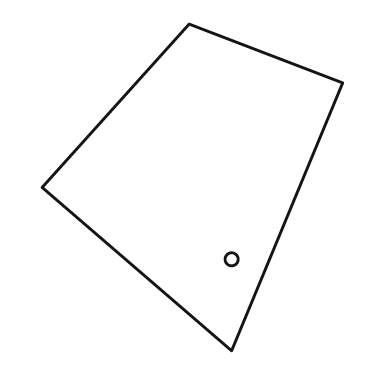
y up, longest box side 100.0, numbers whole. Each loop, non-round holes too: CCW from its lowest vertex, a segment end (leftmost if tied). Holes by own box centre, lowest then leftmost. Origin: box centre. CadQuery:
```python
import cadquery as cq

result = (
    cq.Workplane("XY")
    .moveTo(12.0, -50.0)
    .lineTo(46.0, 32.0)
    .lineTo(-1.0, 50.0)
    .lineTo(-46.0, 0.0)
    .close()
    .moveTo(12.0, -22.0)
    .circle(2.0)
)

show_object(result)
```